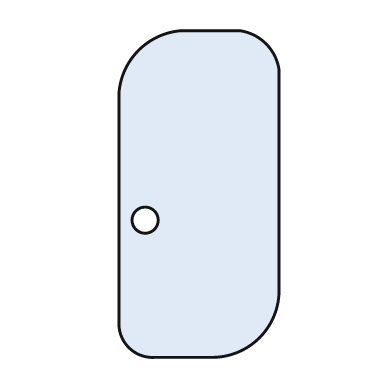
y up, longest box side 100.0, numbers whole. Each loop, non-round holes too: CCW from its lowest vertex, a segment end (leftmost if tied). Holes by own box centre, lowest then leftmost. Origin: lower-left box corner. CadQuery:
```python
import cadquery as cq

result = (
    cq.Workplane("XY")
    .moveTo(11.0, 0.0)
    .lineTo(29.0, 0.0)
    .threePointArc((43.0, 6.0), (49.0, 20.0))
    .lineTo(49.0, 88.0)
    .threePointArc((45.0, 96.0), (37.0, 100.0))
    .lineTo(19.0, 100.0)
    .threePointArc((6.0, 94.0), (0.0, 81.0))
    .lineTo(0.0, 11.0)
    .threePointArc((3.0, 3.0), (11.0, 0.0))
    .close()
    .moveTo(8.0, 42.0)
    .circle(4.0)
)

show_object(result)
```